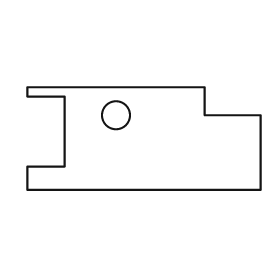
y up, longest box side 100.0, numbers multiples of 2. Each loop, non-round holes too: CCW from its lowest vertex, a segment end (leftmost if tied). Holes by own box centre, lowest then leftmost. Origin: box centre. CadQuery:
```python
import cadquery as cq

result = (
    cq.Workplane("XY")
    .moveTo(-50.0, -22.0)
    .lineTo(50.0, -22.0)
    .lineTo(50.0, 10.0)
    .lineTo(26.0, 10.0)
    .lineTo(26.0, 22.0)
    .lineTo(-50.0, 22.0)
    .lineTo(-50.0, 18.0)
    .lineTo(-34.0, 18.0)
    .lineTo(-34.0, -12.0)
    .lineTo(-50.0, -12.0)
    .close()
    .moveTo(-12.0, 10.0)
    .circle(6.0)
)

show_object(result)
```